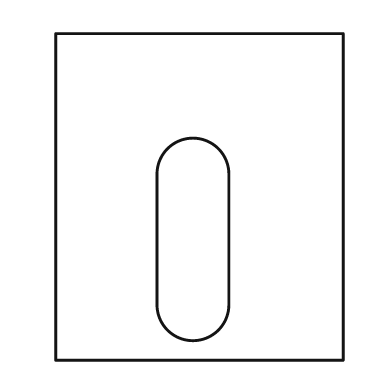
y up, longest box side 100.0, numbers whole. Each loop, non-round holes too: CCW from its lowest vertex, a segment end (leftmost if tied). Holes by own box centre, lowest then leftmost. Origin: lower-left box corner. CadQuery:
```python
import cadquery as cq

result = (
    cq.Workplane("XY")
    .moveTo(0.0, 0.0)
    .lineTo(88.0, 0.0)
    .lineTo(88.0, 100.0)
    .lineTo(0.0, 100.0)
    .close()
    .moveTo(31.0, 17.0)
    .threePointArc((42.0, 6.0), (53.0, 17.0))
    .lineTo(53.0, 57.0)
    .threePointArc((42.0, 68.0), (31.0, 57.0))
    .close()
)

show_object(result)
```